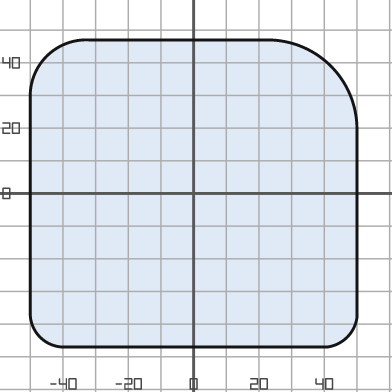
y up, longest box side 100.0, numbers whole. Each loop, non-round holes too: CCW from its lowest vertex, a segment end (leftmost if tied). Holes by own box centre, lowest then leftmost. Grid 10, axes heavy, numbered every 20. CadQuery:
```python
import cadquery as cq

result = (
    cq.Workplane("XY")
    .moveTo(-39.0, -47.0)
    .lineTo(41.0, -47.0)
    .threePointArc((47.0, -44.0), (50.0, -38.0))
    .lineTo(50.0, 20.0)
    .threePointArc((42.0, 39.0), (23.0, 47.0))
    .lineTo(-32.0, 47.0)
    .threePointArc((-45.0, 42.0), (-50.0, 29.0))
    .lineTo(-50.0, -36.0)
    .threePointArc((-47.0, -44.0), (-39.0, -47.0))
    .close()
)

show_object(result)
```